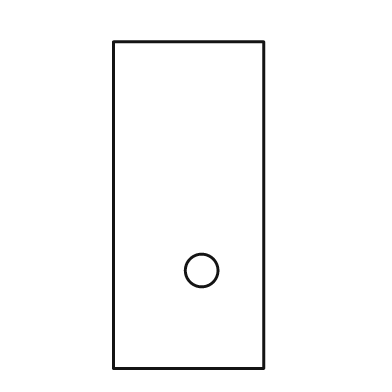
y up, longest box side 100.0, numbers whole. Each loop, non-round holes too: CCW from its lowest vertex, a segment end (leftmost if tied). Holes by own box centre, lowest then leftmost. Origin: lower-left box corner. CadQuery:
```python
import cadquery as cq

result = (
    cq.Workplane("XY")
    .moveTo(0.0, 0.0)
    .lineTo(46.0, 0.0)
    .lineTo(46.0, 100.0)
    .lineTo(0.0, 100.0)
    .close()
    .moveTo(27.0, 30.0)
    .circle(5.0)
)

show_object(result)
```